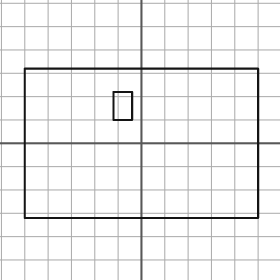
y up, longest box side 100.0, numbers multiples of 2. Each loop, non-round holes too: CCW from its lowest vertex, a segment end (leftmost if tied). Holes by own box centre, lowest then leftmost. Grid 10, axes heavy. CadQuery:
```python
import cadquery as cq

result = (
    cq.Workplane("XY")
    .moveTo(-50.0, -32.0)
    .lineTo(50.0, -32.0)
    .lineTo(50.0, 32.0)
    .lineTo(-50.0, 32.0)
    .close()
    .moveTo(-12.0, 10.0)
    .lineTo(-4.0, 10.0)
    .lineTo(-4.0, 22.0)
    .lineTo(-12.0, 22.0)
    .close()
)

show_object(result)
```